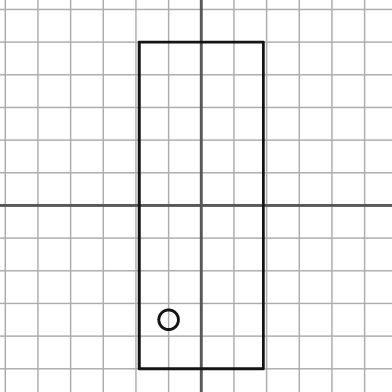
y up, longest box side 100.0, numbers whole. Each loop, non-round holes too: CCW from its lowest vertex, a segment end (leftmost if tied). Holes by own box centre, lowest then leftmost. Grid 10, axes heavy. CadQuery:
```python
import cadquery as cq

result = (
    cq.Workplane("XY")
    .moveTo(-19.0, -50.0)
    .lineTo(19.0, -50.0)
    .lineTo(19.0, 50.0)
    .lineTo(-19.0, 50.0)
    .close()
    .moveTo(-10.0, -35.0)
    .circle(3.0)
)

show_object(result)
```